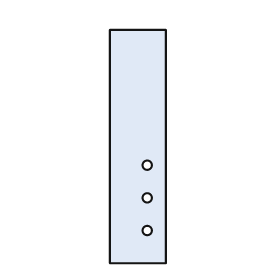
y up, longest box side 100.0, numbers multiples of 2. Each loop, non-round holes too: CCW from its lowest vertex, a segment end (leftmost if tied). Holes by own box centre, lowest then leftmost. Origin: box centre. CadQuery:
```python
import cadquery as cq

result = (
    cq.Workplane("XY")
    .moveTo(-12.0, -50.0)
    .lineTo(12.0, -50.0)
    .lineTo(12.0, 50.0)
    .lineTo(-12.0, 50.0)
    .close()
    .moveTo(4.0, -36.0)
    .circle(2.0)
    .moveTo(4.0, -22.0)
    .circle(2.0)
    .moveTo(4.0, -8.0)
    .circle(2.0)
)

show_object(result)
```